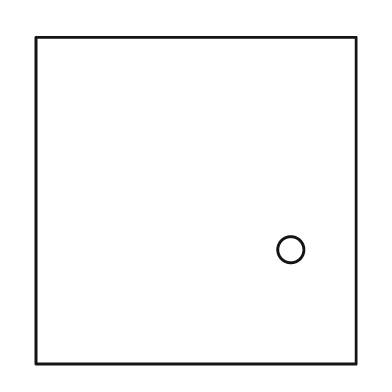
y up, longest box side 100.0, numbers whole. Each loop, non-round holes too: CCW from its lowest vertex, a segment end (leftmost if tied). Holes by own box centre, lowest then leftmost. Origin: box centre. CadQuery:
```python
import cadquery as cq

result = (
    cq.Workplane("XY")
    .moveTo(-49.0, -50.0)
    .lineTo(49.0, -50.0)
    .lineTo(49.0, 50.0)
    .lineTo(-49.0, 50.0)
    .close()
    .moveTo(29.0, -15.0)
    .circle(4.0)
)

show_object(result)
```